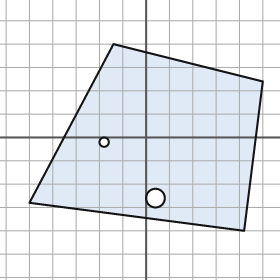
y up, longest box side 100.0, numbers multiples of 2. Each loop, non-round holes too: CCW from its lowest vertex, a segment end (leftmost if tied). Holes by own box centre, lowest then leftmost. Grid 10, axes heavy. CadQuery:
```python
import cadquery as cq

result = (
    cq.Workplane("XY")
    .moveTo(42.0, -40.0)
    .lineTo(50.0, 24.0)
    .lineTo(-14.0, 40.0)
    .lineTo(-50.0, -28.0)
    .close()
    .moveTo(4.0, -26.0)
    .circle(4.0)
    .moveTo(-18.0, -2.0)
    .circle(2.0)
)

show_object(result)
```